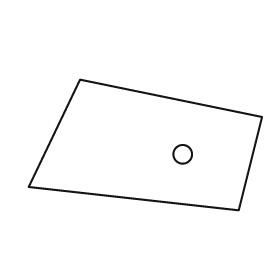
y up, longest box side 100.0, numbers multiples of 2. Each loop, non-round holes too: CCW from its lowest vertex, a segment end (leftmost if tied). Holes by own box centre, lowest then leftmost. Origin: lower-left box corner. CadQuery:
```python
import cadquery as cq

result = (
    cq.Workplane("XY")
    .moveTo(90.0, 0.0)
    .lineTo(100.0, 40.0)
    .lineTo(22.0, 56.0)
    .lineTo(0.0, 10.0)
    .close()
    .moveTo(66.0, 24.0)
    .circle(4.0)
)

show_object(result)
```